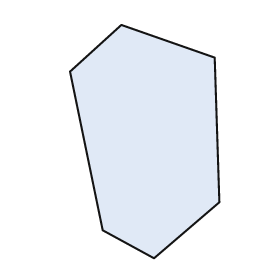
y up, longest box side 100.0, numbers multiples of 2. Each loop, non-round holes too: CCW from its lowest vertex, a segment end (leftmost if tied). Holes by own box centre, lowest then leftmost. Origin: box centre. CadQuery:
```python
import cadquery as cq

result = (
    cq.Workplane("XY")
    .moveTo(4.0, -50.0)
    .lineTo(32.0, -26.0)
    .lineTo(30.0, 36.0)
    .lineTo(-10.0, 50.0)
    .lineTo(-32.0, 30.0)
    .lineTo(-18.0, -38.0)
    .close()
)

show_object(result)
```